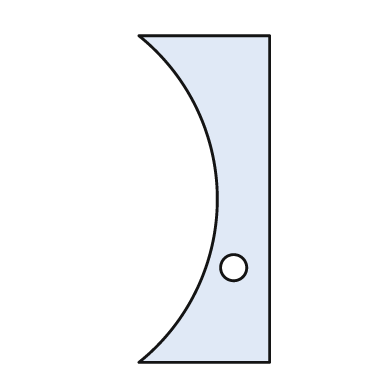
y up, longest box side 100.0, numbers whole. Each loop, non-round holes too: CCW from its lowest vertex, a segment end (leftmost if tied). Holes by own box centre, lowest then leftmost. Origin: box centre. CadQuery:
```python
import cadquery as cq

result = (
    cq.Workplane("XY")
    .moveTo(-20.0, -50.0)
    .lineTo(20.0, -50.0)
    .lineTo(20.0, 50.0)
    .lineTo(-20.0, 50.0)
    .threePointArc((4.0, 0.0), (-20.0, -50.0))
    .close()
    .moveTo(9.0, -21.0)
    .circle(4.0)
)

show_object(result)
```